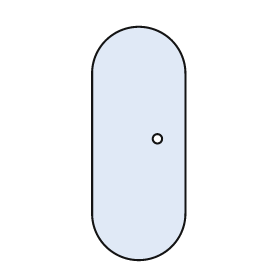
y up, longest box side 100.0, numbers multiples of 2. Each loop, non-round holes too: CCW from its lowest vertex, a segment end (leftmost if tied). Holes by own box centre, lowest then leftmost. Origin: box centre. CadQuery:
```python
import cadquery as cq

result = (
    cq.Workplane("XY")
    .moveTo(-20.0, -30.0)
    .threePointArc((0.0, -50.0), (20.0, -30.0))
    .lineTo(20.0, 30.0)
    .threePointArc((0.0, 50.0), (-20.0, 30.0))
    .close()
    .moveTo(8.0, 2.0)
    .circle(2.0)
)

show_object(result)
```